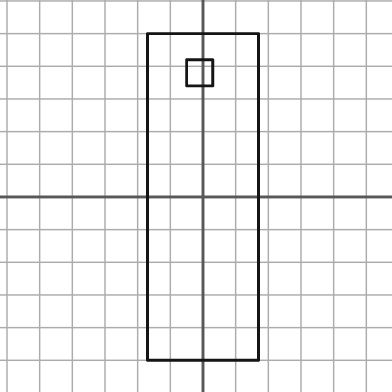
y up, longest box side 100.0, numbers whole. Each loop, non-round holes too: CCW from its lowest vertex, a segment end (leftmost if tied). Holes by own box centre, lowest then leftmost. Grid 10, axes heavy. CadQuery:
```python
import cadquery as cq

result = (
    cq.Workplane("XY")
    .moveTo(-17.0, -50.0)
    .lineTo(17.0, -50.0)
    .lineTo(17.0, 50.0)
    .lineTo(-17.0, 50.0)
    .close()
    .moveTo(-5.0, 34.0)
    .lineTo(3.0, 34.0)
    .lineTo(3.0, 42.0)
    .lineTo(-5.0, 42.0)
    .close()
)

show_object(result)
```